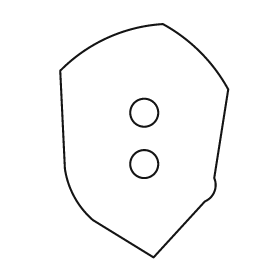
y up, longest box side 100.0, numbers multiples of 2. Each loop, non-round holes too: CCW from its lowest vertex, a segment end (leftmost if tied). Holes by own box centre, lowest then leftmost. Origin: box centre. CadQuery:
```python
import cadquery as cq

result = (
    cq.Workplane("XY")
    .moveTo(4.0, -50.0)
    .lineTo(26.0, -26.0)
    .threePointArc((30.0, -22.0), (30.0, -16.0))
    .lineTo(36.0, 22.0)
    .threePointArc((24.0, 38.0), (8.0, 50.0))
    .threePointArc((-16.0, 44.0), (-36.0, 30.0))
    .lineTo(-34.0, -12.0)
    .threePointArc((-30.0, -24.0), (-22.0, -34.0))
    .close()
    .moveTo(0.0, -10.0)
    .circle(6.0)
    .moveTo(0.0, 12.0)
    .circle(6.0)
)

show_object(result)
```